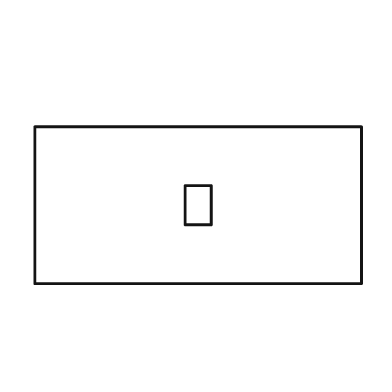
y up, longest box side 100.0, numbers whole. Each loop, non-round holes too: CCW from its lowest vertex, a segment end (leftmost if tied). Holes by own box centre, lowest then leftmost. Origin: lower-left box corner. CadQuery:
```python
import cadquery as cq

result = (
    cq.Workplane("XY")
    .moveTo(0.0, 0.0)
    .lineTo(100.0, 0.0)
    .lineTo(100.0, 48.0)
    .lineTo(0.0, 48.0)
    .close()
    .moveTo(46.0, 18.0)
    .lineTo(54.0, 18.0)
    .lineTo(54.0, 30.0)
    .lineTo(46.0, 30.0)
    .close()
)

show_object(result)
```